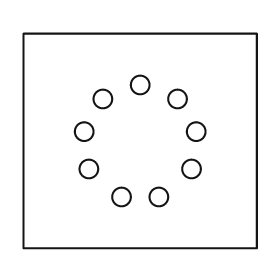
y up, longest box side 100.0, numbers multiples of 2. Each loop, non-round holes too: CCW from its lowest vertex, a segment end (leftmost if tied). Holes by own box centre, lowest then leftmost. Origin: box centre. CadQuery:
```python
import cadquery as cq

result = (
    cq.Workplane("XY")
    .moveTo(-50.0, -46.0)
    .lineTo(50.0, -46.0)
    .lineTo(50.0, 46.0)
    .lineTo(-50.0, 46.0)
    .close()
    .moveTo(-8.0, -24.0)
    .circle(4.0)
    .moveTo(8.0, -24.0)
    .circle(4.0)
    .moveTo(-22.0, -12.0)
    .circle(4.0)
    .moveTo(22.0, -12.0)
    .circle(4.0)
    .moveTo(-24.0, 4.0)
    .circle(4.0)
    .moveTo(24.0, 4.0)
    .circle(4.0)
    .moveTo(-16.0, 18.0)
    .circle(4.0)
    .moveTo(16.0, 18.0)
    .circle(4.0)
    .moveTo(0.0, 24.0)
    .circle(4.0)
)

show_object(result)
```